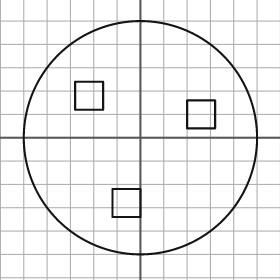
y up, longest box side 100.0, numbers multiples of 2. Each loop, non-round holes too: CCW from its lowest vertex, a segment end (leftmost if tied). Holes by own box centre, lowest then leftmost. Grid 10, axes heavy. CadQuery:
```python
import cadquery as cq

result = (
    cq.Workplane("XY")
    .moveTo(0.0, 0.0)
    .circle(50.0)
    .moveTo(-12.0, -34.0)
    .lineTo(0.0, -34.0)
    .lineTo(0.0, -22.0)
    .lineTo(-12.0, -22.0)
    .close()
    .moveTo(20.0, 4.0)
    .lineTo(32.0, 4.0)
    .lineTo(32.0, 16.0)
    .lineTo(20.0, 16.0)
    .close()
    .moveTo(-28.0, 12.0)
    .lineTo(-16.0, 12.0)
    .lineTo(-16.0, 24.0)
    .lineTo(-28.0, 24.0)
    .close()
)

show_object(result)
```